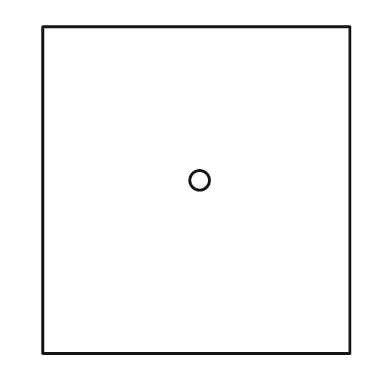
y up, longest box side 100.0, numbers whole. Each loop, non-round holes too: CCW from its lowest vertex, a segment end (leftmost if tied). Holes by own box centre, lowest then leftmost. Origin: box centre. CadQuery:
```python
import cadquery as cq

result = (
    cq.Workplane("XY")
    .moveTo(-47.0, -50.0)
    .lineTo(47.0, -50.0)
    .lineTo(47.0, 50.0)
    .lineTo(-47.0, 50.0)
    .close()
    .moveTo(1.0, 3.0)
    .circle(3.0)
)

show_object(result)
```